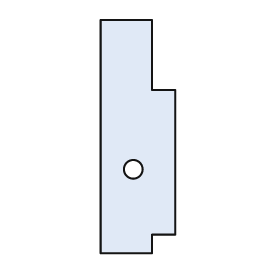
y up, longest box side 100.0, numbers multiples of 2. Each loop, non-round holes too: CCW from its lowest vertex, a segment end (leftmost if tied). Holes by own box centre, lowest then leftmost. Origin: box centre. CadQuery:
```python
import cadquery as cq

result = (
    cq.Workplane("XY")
    .moveTo(-16.0, -50.0)
    .lineTo(6.0, -50.0)
    .lineTo(6.0, -42.0)
    .lineTo(16.0, -42.0)
    .lineTo(16.0, 20.0)
    .lineTo(6.0, 20.0)
    .lineTo(6.0, 50.0)
    .lineTo(-16.0, 50.0)
    .close()
    .moveTo(-2.0, -14.0)
    .circle(4.0)
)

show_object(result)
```